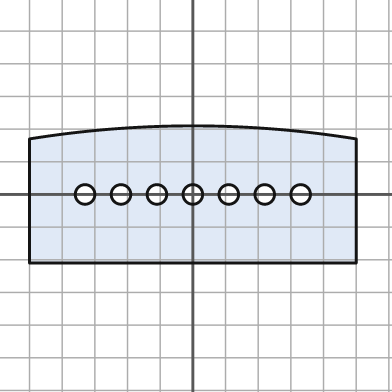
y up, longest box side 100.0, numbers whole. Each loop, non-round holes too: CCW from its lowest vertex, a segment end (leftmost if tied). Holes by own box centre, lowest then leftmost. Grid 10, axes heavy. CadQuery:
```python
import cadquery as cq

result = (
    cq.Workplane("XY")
    .moveTo(-50.0, -21.0)
    .lineTo(50.0, -21.0)
    .lineTo(50.0, 17.0)
    .threePointArc((0.0, 21.0), (-50.0, 17.0))
    .close()
    .moveTo(-33.0, 0.0)
    .circle(3.0)
    .moveTo(-22.0, 0.0)
    .circle(3.0)
    .moveTo(-11.0, 0.0)
    .circle(3.0)
    .moveTo(0.0, 0.0)
    .circle(3.0)
    .moveTo(11.0, 0.0)
    .circle(3.0)
    .moveTo(22.0, 0.0)
    .circle(3.0)
    .moveTo(33.0, 0.0)
    .circle(3.0)
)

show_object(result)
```